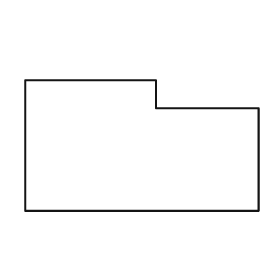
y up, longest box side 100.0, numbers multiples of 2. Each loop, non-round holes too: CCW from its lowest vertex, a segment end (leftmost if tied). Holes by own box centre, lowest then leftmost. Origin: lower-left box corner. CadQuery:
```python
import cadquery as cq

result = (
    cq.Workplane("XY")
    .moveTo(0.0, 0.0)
    .lineTo(100.0, 0.0)
    .lineTo(100.0, 44.0)
    .lineTo(56.0, 44.0)
    .lineTo(56.0, 56.0)
    .lineTo(0.0, 56.0)
    .close()
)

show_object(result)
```